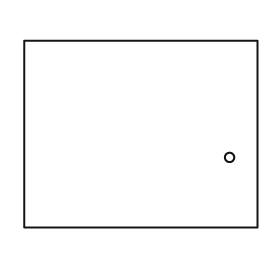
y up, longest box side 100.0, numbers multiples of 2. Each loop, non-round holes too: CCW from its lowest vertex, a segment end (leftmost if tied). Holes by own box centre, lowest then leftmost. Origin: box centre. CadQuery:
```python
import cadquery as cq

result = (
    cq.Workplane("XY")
    .moveTo(-50.0, -40.0)
    .lineTo(50.0, -40.0)
    .lineTo(50.0, 40.0)
    .lineTo(-50.0, 40.0)
    .close()
    .moveTo(38.0, -10.0)
    .circle(2.0)
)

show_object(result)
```